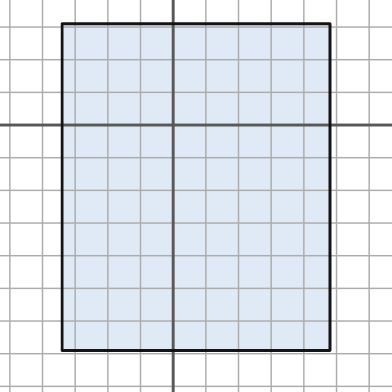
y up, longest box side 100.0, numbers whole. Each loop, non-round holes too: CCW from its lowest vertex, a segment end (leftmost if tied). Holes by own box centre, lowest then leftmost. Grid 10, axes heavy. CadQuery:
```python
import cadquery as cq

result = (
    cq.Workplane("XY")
    .moveTo(-34.0, -69.0)
    .lineTo(48.0, -69.0)
    .lineTo(48.0, 31.0)
    .lineTo(-34.0, 31.0)
    .close()
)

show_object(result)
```